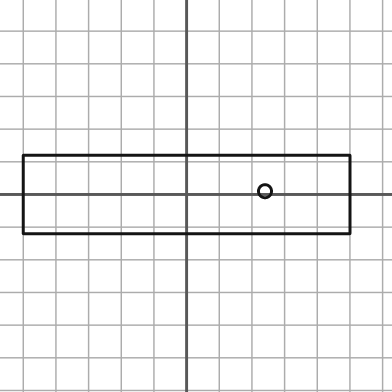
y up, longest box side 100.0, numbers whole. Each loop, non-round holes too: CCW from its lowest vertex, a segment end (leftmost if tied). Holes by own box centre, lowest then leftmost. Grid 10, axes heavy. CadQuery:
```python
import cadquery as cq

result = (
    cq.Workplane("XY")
    .moveTo(-50.0, -12.0)
    .lineTo(50.0, -12.0)
    .lineTo(50.0, 12.0)
    .lineTo(-50.0, 12.0)
    .close()
    .moveTo(24.0, 1.0)
    .circle(2.0)
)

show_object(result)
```